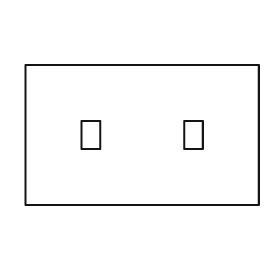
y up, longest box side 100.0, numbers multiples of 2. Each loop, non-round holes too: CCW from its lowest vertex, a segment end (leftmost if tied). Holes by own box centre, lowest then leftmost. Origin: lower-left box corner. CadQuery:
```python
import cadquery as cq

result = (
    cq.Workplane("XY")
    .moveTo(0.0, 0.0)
    .lineTo(100.0, 0.0)
    .lineTo(100.0, 60.0)
    .lineTo(0.0, 60.0)
    .close()
    .moveTo(24.0, 24.0)
    .lineTo(32.0, 24.0)
    .lineTo(32.0, 36.0)
    .lineTo(24.0, 36.0)
    .close()
    .moveTo(68.0, 24.0)
    .lineTo(76.0, 24.0)
    .lineTo(76.0, 36.0)
    .lineTo(68.0, 36.0)
    .close()
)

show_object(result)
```